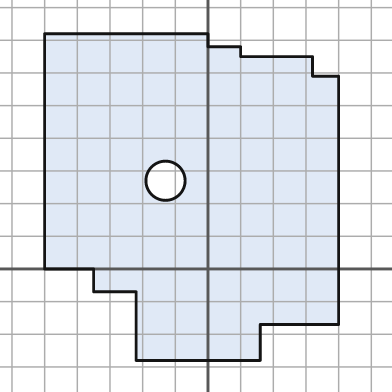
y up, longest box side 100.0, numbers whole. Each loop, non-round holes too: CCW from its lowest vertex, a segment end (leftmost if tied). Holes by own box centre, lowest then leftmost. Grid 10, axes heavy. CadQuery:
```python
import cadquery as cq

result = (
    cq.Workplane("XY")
    .moveTo(-22.0, -28.0)
    .lineTo(16.0, -28.0)
    .lineTo(16.0, -17.0)
    .lineTo(40.0, -17.0)
    .lineTo(40.0, 59.0)
    .lineTo(32.0, 59.0)
    .lineTo(32.0, 65.0)
    .lineTo(10.0, 65.0)
    .lineTo(10.0, 68.0)
    .lineTo(0.0, 68.0)
    .lineTo(0.0, 72.0)
    .lineTo(-50.0, 72.0)
    .lineTo(-50.0, 0.0)
    .lineTo(-35.0, 0.0)
    .lineTo(-35.0, -7.0)
    .lineTo(-22.0, -7.0)
    .close()
    .moveTo(-13.0, 27.0)
    .circle(6.0)
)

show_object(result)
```